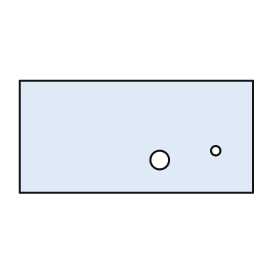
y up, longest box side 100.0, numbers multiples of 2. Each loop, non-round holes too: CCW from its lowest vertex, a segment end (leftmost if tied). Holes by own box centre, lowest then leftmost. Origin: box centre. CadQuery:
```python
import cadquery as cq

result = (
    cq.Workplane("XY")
    .moveTo(-50.0, -24.0)
    .lineTo(50.0, -24.0)
    .lineTo(50.0, 24.0)
    .lineTo(-50.0, 24.0)
    .close()
    .moveTo(10.0, -10.0)
    .circle(4.0)
    .moveTo(34.0, -6.0)
    .circle(2.0)
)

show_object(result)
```